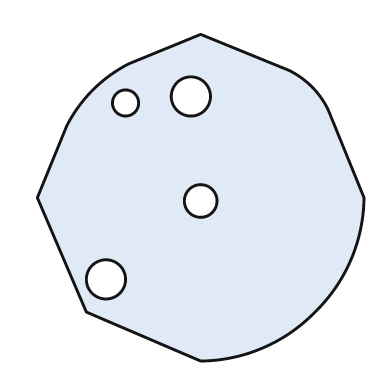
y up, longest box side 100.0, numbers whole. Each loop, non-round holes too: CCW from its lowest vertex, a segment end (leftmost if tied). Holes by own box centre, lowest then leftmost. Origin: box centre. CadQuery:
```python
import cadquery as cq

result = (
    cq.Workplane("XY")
    .moveTo(0.0, -50.0)
    .threePointArc((19.0, -46.0), (35.0, -35.0))
    .threePointArc((46.0, -19.0), (50.0, 0.0))
    .lineTo(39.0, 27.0)
    .threePointArc((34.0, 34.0), (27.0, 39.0))
    .lineTo(0.0, 50.0)
    .lineTo(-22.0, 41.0)
    .threePointArc((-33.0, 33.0), (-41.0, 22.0))
    .lineTo(-50.0, 0.0)
    .lineTo(-35.0, -35.0)
    .close()
    .moveTo(-29.0, -25.0)
    .circle(6.0)
    .moveTo(0.0, -1.0)
    .circle(5.0)
    .moveTo(-23.0, 29.0)
    .circle(4.0)
    .moveTo(-3.0, 31.0)
    .circle(6.0)
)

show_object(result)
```